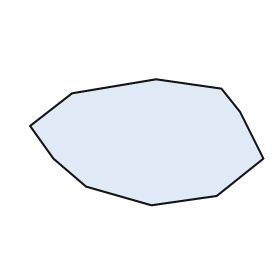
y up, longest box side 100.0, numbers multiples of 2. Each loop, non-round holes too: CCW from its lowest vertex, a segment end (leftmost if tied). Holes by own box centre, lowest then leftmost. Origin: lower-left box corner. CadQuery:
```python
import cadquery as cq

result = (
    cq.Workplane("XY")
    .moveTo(52.0, 0.0)
    .lineTo(80.0, 4.0)
    .lineTo(100.0, 20.0)
    .lineTo(90.0, 40.0)
    .lineTo(82.0, 50.0)
    .lineTo(54.0, 54.0)
    .lineTo(18.0, 48.0)
    .lineTo(0.0, 34.0)
    .lineTo(10.0, 20.0)
    .lineTo(24.0, 8.0)
    .close()
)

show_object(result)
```